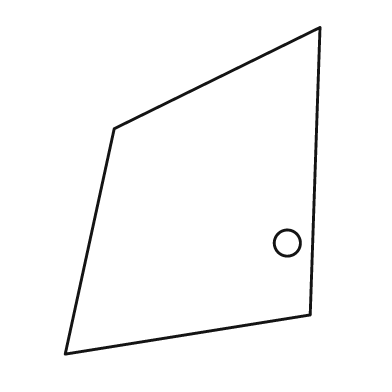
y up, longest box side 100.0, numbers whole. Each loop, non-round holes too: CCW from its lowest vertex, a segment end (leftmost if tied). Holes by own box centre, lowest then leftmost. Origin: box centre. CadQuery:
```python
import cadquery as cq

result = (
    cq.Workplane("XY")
    .moveTo(-39.0, -50.0)
    .lineTo(36.0, -38.0)
    .lineTo(39.0, 50.0)
    .lineTo(-24.0, 19.0)
    .close()
    .moveTo(29.0, -16.0)
    .circle(4.0)
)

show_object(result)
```